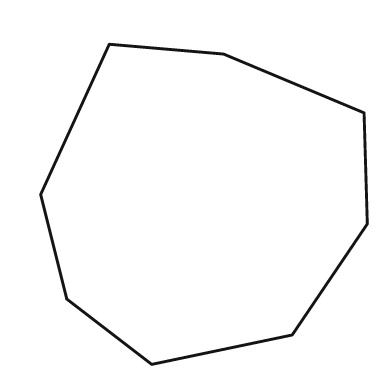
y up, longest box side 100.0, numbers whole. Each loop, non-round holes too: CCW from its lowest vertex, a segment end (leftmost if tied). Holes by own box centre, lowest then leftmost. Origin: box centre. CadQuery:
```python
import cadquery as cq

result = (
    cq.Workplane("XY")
    .moveTo(-16.0, -49.0)
    .lineTo(27.0, -40.0)
    .lineTo(50.0, -6.0)
    .lineTo(49.0, 28.0)
    .lineTo(6.0, 46.0)
    .lineTo(-29.0, 49.0)
    .lineTo(-50.0, 3.0)
    .lineTo(-42.0, -29.0)
    .close()
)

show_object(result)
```